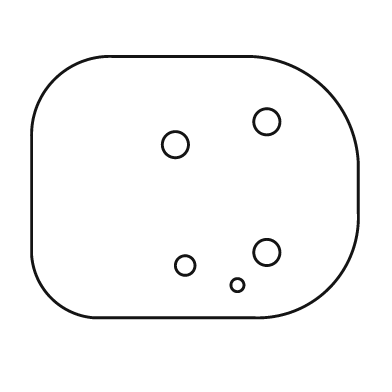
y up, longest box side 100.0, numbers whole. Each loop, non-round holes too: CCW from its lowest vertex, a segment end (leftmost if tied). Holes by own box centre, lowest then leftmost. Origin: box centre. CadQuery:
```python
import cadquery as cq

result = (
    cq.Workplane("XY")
    .moveTo(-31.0, -40.0)
    .lineTo(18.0, -40.0)
    .threePointArc((41.0, -31.0), (50.0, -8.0))
    .lineTo(50.0, 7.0)
    .threePointArc((40.0, 30.0), (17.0, 40.0))
    .lineTo(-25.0, 40.0)
    .threePointArc((-43.0, 33.0), (-50.0, 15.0))
    .lineTo(-50.0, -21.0)
    .threePointArc((-44.0, -34.0), (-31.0, -40.0))
    .close()
    .moveTo(13.0, -30.0)
    .circle(2.0)
    .moveTo(-3.0, -24.0)
    .circle(3.0)
    .moveTo(22.0, -20.0)
    .circle(4.0)
    .moveTo(-6.0, 13.0)
    .circle(4.0)
    .moveTo(22.0, 20.0)
    .circle(4.0)
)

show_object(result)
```